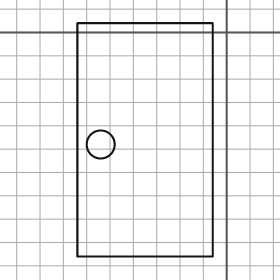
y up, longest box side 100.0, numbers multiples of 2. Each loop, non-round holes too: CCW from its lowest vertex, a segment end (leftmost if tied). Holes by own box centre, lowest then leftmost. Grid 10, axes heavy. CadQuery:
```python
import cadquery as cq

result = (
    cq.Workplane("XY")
    .moveTo(-64.0, -96.0)
    .lineTo(-6.0, -96.0)
    .lineTo(-6.0, 4.0)
    .lineTo(-64.0, 4.0)
    .close()
    .moveTo(-54.0, -48.0)
    .circle(6.0)
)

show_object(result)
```